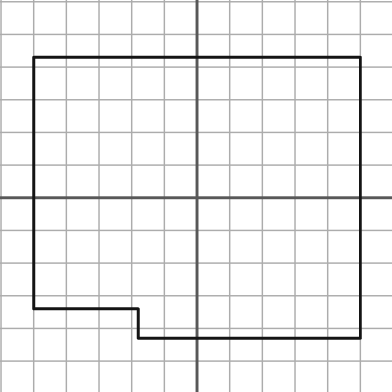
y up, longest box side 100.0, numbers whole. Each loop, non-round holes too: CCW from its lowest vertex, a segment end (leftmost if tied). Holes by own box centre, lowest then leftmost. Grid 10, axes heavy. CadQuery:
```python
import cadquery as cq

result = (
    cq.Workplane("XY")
    .moveTo(-18.0, -43.0)
    .lineTo(50.0, -43.0)
    .lineTo(50.0, 43.0)
    .lineTo(-50.0, 43.0)
    .lineTo(-50.0, -34.0)
    .lineTo(-18.0, -34.0)
    .close()
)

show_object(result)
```